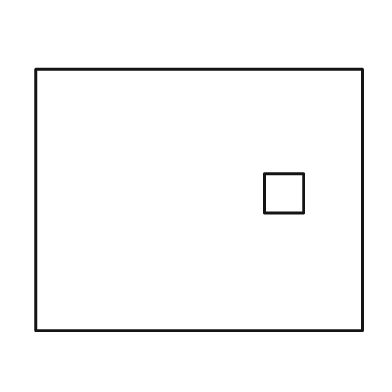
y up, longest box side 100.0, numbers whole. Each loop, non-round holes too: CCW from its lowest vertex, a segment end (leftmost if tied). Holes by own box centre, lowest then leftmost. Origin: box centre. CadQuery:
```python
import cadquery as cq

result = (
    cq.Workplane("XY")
    .moveTo(-50.0, -40.0)
    .lineTo(50.0, -40.0)
    .lineTo(50.0, 40.0)
    .lineTo(-50.0, 40.0)
    .close()
    .moveTo(20.0, -4.0)
    .lineTo(32.0, -4.0)
    .lineTo(32.0, 8.0)
    .lineTo(20.0, 8.0)
    .close()
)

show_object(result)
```